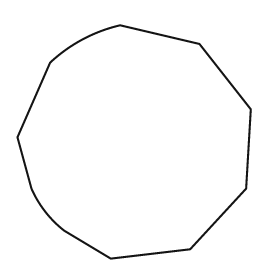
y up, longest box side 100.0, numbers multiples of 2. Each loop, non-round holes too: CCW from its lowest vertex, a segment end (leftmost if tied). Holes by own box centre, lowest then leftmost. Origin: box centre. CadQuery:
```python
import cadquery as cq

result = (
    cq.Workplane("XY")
    .moveTo(-10.0, -50.0)
    .lineTo(24.0, -46.0)
    .lineTo(48.0, -20.0)
    .lineTo(50.0, 14.0)
    .lineTo(28.0, 42.0)
    .lineTo(-6.0, 50.0)
    .threePointArc((-22.0, 44.0), (-36.0, 34.0))
    .lineTo(-50.0, 2.0)
    .lineTo(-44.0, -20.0)
    .threePointArc((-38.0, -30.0), (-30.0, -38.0))
    .close()
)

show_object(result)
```